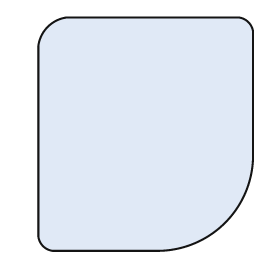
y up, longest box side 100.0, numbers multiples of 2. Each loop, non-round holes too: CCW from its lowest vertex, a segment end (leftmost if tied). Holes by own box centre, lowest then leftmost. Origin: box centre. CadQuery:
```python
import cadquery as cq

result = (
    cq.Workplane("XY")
    .moveTo(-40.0, -50.0)
    .lineTo(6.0, -50.0)
    .threePointArc((34.0, -38.0), (46.0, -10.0))
    .lineTo(46.0, 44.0)
    .threePointArc((44.0, 48.0), (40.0, 50.0))
    .lineTo(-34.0, 50.0)
    .threePointArc((-42.0, 46.0), (-46.0, 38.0))
    .lineTo(-46.0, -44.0)
    .threePointArc((-44.0, -48.0), (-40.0, -50.0))
    .close()
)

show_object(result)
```